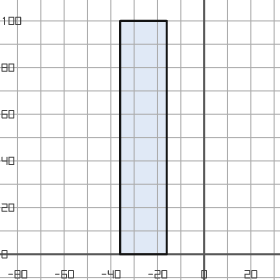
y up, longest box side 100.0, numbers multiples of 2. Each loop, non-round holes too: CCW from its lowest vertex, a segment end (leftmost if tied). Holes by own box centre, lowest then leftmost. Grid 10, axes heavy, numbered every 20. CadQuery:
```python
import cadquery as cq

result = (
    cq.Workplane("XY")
    .moveTo(-36.0, 0.0)
    .lineTo(-16.0, 0.0)
    .lineTo(-16.0, 100.0)
    .lineTo(-36.0, 100.0)
    .close()
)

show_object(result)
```